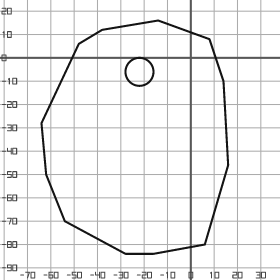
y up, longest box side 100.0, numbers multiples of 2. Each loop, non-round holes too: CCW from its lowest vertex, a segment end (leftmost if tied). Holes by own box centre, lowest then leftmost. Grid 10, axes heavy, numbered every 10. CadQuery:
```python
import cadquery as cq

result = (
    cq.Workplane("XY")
    .moveTo(-28.0, -84.0)
    .lineTo(-16.0, -84.0)
    .lineTo(6.0, -80.0)
    .lineTo(16.0, -46.0)
    .lineTo(14.0, -10.0)
    .lineTo(8.0, 8.0)
    .lineTo(-14.0, 16.0)
    .lineTo(-38.0, 12.0)
    .lineTo(-48.0, 6.0)
    .lineTo(-64.0, -28.0)
    .lineTo(-62.0, -50.0)
    .lineTo(-54.0, -70.0)
    .close()
    .moveTo(-22.0, -6.0)
    .circle(6.0)
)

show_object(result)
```